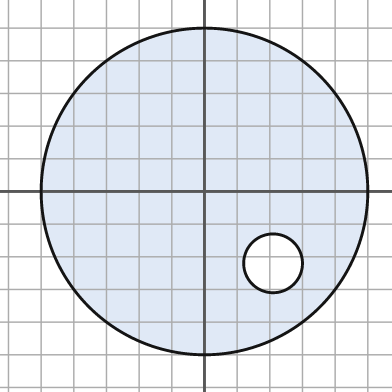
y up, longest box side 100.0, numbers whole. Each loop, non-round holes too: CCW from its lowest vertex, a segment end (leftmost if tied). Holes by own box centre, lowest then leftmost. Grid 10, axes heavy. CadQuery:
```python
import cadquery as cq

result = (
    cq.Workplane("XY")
    .moveTo(0.0, 0.0)
    .circle(50.0)
    .moveTo(21.0, -22.0)
    .circle(9.0)
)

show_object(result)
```